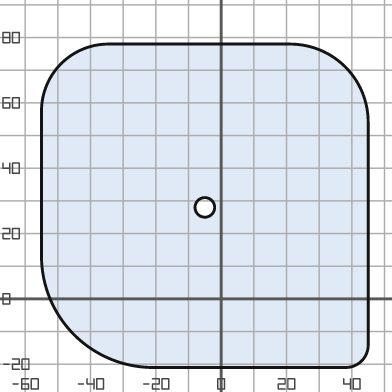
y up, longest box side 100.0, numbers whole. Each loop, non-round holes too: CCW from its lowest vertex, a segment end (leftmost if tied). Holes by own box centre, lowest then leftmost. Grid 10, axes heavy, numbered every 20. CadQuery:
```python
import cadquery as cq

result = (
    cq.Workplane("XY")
    .moveTo(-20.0, -21.0)
    .lineTo(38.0, -21.0)
    .threePointArc((43.0, -19.0), (45.0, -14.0))
    .lineTo(45.0, 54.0)
    .threePointArc((38.0, 71.0), (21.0, 78.0))
    .lineTo(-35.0, 78.0)
    .threePointArc((-49.0, 72.0), (-55.0, 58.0))
    .lineTo(-55.0, 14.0)
    .threePointArc((-45.0, -11.0), (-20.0, -21.0))
    .close()
    .moveTo(-5.0, 28.0)
    .circle(3.0)
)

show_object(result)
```